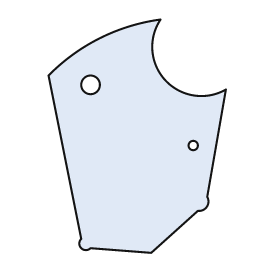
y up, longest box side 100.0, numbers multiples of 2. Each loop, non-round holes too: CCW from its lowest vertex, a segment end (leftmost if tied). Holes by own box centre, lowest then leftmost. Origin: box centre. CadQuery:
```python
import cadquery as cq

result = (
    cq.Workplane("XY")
    .moveTo(6.0, -50.0)
    .lineTo(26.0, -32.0)
    .threePointArc((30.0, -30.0), (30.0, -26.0))
    .lineTo(38.0, 20.0)
    .threePointArc((12.0, 24.0), (10.0, 50.0))
    .threePointArc((-16.0, 42.0), (-38.0, 26.0))
    .lineTo(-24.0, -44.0)
    .threePointArc((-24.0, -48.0), (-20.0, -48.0))
    .close()
    .moveTo(24.0, -4.0)
    .circle(2.0)
    .moveTo(-20.0, 22.0)
    .circle(4.0)
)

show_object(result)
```